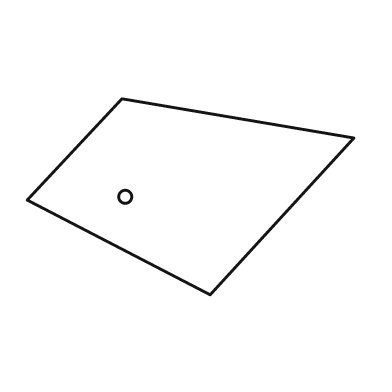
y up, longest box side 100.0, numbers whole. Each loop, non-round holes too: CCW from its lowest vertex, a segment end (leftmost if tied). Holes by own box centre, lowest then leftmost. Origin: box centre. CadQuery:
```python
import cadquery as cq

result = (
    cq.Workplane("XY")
    .moveTo(6.0, -30.0)
    .lineTo(50.0, 18.0)
    .lineTo(-21.0, 30.0)
    .lineTo(-50.0, -1.0)
    .close()
    .moveTo(-20.0, 0.0)
    .circle(2.0)
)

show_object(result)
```